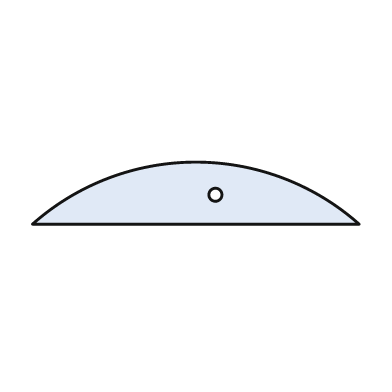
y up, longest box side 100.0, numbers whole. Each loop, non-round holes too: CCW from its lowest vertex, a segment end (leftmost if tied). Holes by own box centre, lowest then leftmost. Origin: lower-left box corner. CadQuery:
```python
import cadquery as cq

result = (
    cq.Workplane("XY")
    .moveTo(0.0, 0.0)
    .lineTo(100.0, 0.0)
    .threePointArc((50.0, 19.0), (0.0, 0.0))
    .close()
    .moveTo(56.0, 9.0)
    .circle(2.0)
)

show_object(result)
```